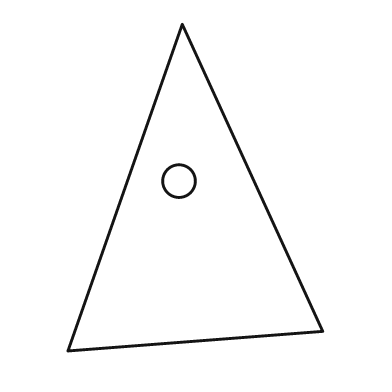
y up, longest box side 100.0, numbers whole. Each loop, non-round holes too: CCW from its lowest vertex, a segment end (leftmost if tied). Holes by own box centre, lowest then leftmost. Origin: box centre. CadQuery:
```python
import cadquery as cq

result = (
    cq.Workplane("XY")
    .moveTo(-39.0, -50.0)
    .lineTo(39.0, -44.0)
    .lineTo(-4.0, 50.0)
    .close()
    .moveTo(-5.0, 2.0)
    .circle(5.0)
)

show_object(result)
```